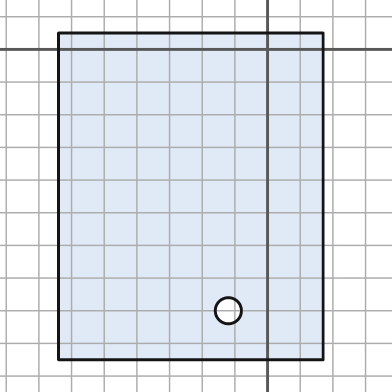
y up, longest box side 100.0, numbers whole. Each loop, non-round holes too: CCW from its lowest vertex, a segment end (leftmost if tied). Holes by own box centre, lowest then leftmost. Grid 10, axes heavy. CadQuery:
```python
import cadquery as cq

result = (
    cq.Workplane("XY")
    .moveTo(-64.0, -95.0)
    .lineTo(17.0, -95.0)
    .lineTo(17.0, 5.0)
    .lineTo(-64.0, 5.0)
    .close()
    .moveTo(-12.0, -80.0)
    .circle(4.0)
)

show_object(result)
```